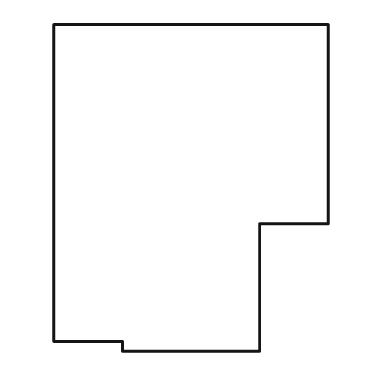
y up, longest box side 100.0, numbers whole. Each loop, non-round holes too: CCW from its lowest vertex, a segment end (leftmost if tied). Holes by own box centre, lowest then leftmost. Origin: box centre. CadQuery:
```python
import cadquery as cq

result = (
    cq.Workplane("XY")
    .moveTo(-21.0, -50.0)
    .lineTo(21.0, -50.0)
    .lineTo(21.0, -11.0)
    .lineTo(42.0, -11.0)
    .lineTo(42.0, 50.0)
    .lineTo(-42.0, 50.0)
    .lineTo(-42.0, -47.0)
    .lineTo(-21.0, -47.0)
    .close()
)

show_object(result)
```